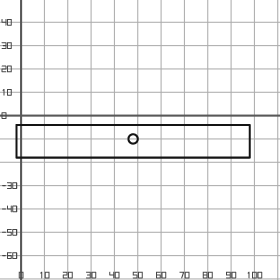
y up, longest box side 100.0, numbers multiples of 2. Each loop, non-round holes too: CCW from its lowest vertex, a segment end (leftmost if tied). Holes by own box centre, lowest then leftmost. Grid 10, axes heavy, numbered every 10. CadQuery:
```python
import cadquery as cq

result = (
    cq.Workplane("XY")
    .moveTo(-2.0, -18.0)
    .lineTo(98.0, -18.0)
    .lineTo(98.0, -4.0)
    .lineTo(-2.0, -4.0)
    .close()
    .moveTo(48.0, -10.0)
    .circle(2.0)
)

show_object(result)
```